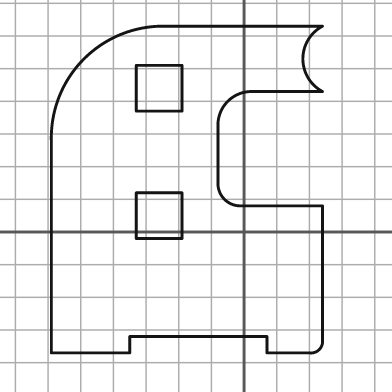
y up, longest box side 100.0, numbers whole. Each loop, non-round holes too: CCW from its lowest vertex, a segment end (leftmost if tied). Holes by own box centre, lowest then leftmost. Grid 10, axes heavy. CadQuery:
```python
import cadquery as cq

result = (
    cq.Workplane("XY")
    .moveTo(-59.0, -37.0)
    .lineTo(-35.0, -37.0)
    .lineTo(-35.0, -32.0)
    .lineTo(7.0, -32.0)
    .lineTo(7.0, -37.0)
    .lineTo(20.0, -37.0)
    .threePointArc((23.0, -36.0), (24.0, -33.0))
    .lineTo(24.0, 8.0)
    .lineTo(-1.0, 8.0)
    .threePointArc((-6.0, 10.0), (-8.0, 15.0))
    .lineTo(-8.0, 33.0)
    .threePointArc((-5.0, 40.0), (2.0, 43.0))
    .lineTo(24.0, 43.0)
    .threePointArc((18.0, 53.0), (24.0, 63.0))
    .lineTo(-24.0, 63.0)
    .threePointArc((-49.0, 53.0), (-59.0, 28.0))
    .close()
    .moveTo(-33.0, -2.0)
    .lineTo(-19.0, -2.0)
    .lineTo(-19.0, 12.0)
    .lineTo(-33.0, 12.0)
    .close()
    .moveTo(-33.0, 37.0)
    .lineTo(-19.0, 37.0)
    .lineTo(-19.0, 51.0)
    .lineTo(-33.0, 51.0)
    .close()
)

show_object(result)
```